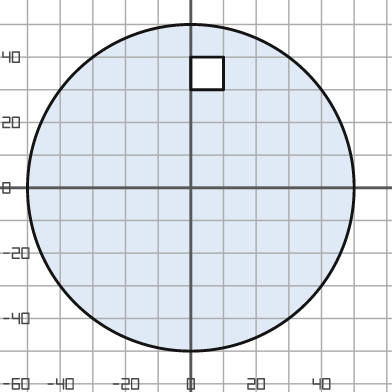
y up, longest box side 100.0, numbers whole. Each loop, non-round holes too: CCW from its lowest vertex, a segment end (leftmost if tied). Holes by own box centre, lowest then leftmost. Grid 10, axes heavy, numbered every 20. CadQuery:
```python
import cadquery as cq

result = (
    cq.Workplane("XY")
    .moveTo(0.0, 0.0)
    .circle(50.0)
    .moveTo(0.0, 30.0)
    .lineTo(10.0, 30.0)
    .lineTo(10.0, 40.0)
    .lineTo(0.0, 40.0)
    .close()
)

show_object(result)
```